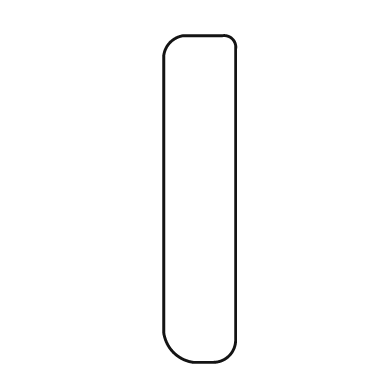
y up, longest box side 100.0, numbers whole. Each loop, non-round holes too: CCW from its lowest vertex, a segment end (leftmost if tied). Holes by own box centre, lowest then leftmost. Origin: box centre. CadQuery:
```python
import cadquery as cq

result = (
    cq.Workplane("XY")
    .moveTo(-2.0, -50.0)
    .lineTo(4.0, -50.0)
    .threePointArc((9.0, -48.0), (11.0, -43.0))
    .lineTo(11.0, 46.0)
    .threePointArc((10.0, 49.0), (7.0, 50.0))
    .lineTo(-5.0, 50.0)
    .threePointArc((-9.0, 48.0), (-11.0, 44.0))
    .lineTo(-11.0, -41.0)
    .threePointArc((-8.0, -47.0), (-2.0, -50.0))
    .close()
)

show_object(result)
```